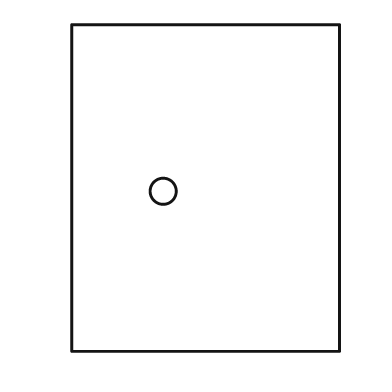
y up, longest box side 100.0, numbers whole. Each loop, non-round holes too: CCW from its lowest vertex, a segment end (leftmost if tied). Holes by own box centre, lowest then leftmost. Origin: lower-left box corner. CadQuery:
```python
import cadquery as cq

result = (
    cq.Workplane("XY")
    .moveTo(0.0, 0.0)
    .lineTo(82.0, 0.0)
    .lineTo(82.0, 100.0)
    .lineTo(0.0, 100.0)
    .close()
    .moveTo(28.0, 49.0)
    .circle(4.0)
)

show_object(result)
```